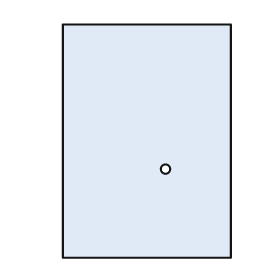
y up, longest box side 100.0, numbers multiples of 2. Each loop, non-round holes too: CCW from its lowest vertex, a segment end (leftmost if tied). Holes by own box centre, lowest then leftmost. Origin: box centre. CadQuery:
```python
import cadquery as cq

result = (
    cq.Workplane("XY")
    .moveTo(-36.0, -50.0)
    .lineTo(36.0, -50.0)
    .lineTo(36.0, 50.0)
    .lineTo(-36.0, 50.0)
    .close()
    .moveTo(8.0, -12.0)
    .circle(2.0)
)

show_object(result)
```